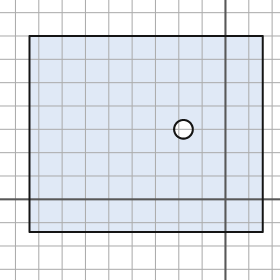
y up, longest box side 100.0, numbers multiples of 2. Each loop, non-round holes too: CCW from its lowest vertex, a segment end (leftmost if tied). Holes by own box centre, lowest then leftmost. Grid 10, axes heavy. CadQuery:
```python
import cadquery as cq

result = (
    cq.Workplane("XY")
    .moveTo(-84.0, -14.0)
    .lineTo(16.0, -14.0)
    .lineTo(16.0, 70.0)
    .lineTo(-84.0, 70.0)
    .close()
    .moveTo(-18.0, 30.0)
    .circle(4.0)
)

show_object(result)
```